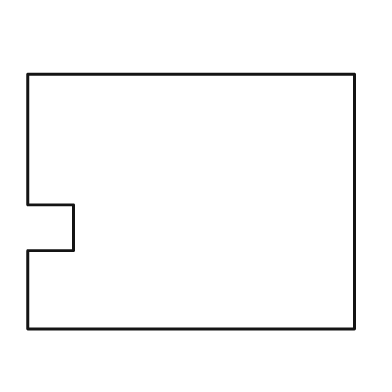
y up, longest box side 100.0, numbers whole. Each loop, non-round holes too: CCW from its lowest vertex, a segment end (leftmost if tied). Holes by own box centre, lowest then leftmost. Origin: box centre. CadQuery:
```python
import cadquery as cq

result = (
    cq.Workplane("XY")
    .moveTo(-50.0, -39.0)
    .lineTo(50.0, -39.0)
    .lineTo(50.0, 39.0)
    .lineTo(-50.0, 39.0)
    .lineTo(-50.0, -1.0)
    .lineTo(-36.0, -1.0)
    .lineTo(-36.0, -15.0)
    .lineTo(-50.0, -15.0)
    .close()
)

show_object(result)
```